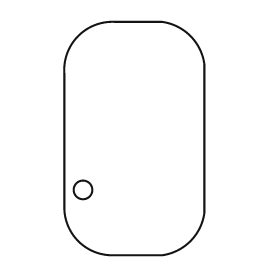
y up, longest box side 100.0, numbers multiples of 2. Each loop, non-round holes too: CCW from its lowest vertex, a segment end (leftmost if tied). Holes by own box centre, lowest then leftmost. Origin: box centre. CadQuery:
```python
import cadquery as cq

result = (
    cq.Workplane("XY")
    .moveTo(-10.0, -50.0)
    .lineTo(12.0, -50.0)
    .threePointArc((24.0, -44.0), (30.0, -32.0))
    .lineTo(30.0, 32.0)
    .threePointArc((24.0, 44.0), (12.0, 50.0))
    .lineTo(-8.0, 50.0)
    .threePointArc((-24.0, 44.0), (-30.0, 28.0))
    .lineTo(-30.0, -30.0)
    .threePointArc((-24.0, -44.0), (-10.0, -50.0))
    .close()
    .moveTo(-22.0, -22.0)
    .circle(4.0)
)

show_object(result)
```